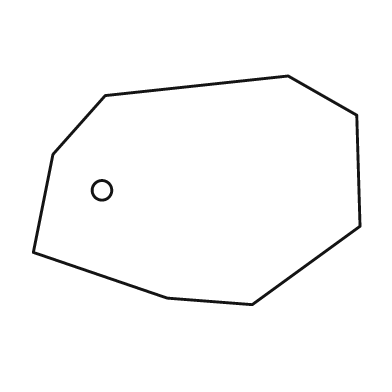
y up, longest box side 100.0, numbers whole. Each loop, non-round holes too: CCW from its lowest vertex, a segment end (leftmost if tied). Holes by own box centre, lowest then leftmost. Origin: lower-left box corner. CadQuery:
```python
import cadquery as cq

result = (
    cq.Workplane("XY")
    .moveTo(67.0, 0.0)
    .lineTo(100.0, 24.0)
    .lineTo(99.0, 58.0)
    .lineTo(78.0, 70.0)
    .lineTo(22.0, 64.0)
    .lineTo(6.0, 46.0)
    .lineTo(0.0, 16.0)
    .lineTo(41.0, 2.0)
    .close()
    .moveTo(21.0, 35.0)
    .circle(3.0)
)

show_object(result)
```